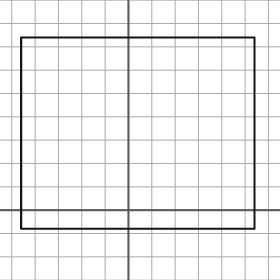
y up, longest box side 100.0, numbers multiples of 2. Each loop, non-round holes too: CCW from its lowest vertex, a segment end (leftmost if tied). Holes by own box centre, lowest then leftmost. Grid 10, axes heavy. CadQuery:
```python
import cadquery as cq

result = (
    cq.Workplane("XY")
    .moveTo(-46.0, -8.0)
    .lineTo(54.0, -8.0)
    .lineTo(54.0, 74.0)
    .lineTo(-46.0, 74.0)
    .close()
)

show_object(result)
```